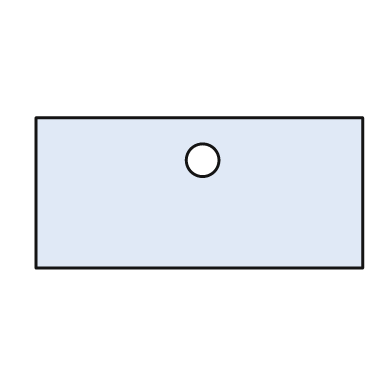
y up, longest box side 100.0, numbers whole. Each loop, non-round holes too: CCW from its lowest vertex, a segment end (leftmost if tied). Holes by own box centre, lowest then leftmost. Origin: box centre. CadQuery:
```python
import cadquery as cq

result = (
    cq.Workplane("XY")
    .moveTo(-50.0, -23.0)
    .lineTo(50.0, -23.0)
    .lineTo(50.0, 23.0)
    .lineTo(-50.0, 23.0)
    .close()
    .moveTo(1.0, 10.0)
    .circle(5.0)
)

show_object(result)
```